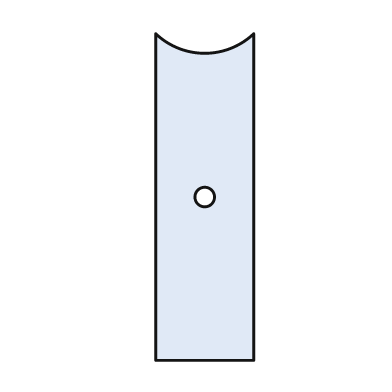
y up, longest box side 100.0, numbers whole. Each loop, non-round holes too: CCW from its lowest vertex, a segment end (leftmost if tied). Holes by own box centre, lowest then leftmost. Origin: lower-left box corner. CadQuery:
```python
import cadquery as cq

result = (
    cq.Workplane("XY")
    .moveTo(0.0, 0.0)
    .lineTo(30.0, 0.0)
    .lineTo(30.0, 100.0)
    .threePointArc((15.0, 94.0), (0.0, 100.0))
    .close()
    .moveTo(15.0, 50.0)
    .circle(3.0)
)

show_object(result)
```